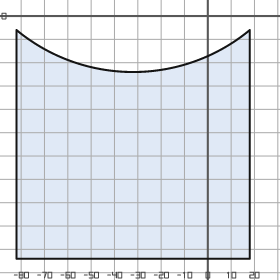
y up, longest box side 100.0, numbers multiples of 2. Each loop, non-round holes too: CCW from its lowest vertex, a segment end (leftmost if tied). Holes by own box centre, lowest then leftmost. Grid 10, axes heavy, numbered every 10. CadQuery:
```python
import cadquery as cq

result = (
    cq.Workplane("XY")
    .moveTo(-82.0, -104.0)
    .lineTo(18.0, -104.0)
    .lineTo(18.0, -6.0)
    .threePointArc((-32.0, -24.0), (-82.0, -6.0))
    .close()
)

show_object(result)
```